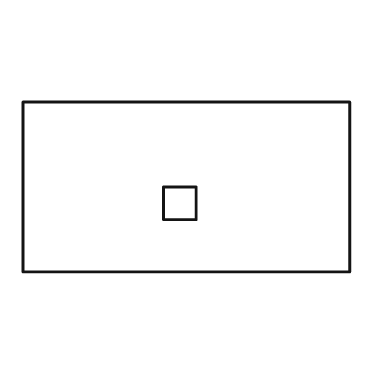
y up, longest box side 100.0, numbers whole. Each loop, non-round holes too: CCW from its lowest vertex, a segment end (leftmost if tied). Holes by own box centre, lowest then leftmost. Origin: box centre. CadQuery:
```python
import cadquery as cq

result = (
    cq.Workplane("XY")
    .moveTo(-50.0, -26.0)
    .lineTo(50.0, -26.0)
    .lineTo(50.0, 26.0)
    .lineTo(-50.0, 26.0)
    .close()
    .moveTo(-7.0, -10.0)
    .lineTo(3.0, -10.0)
    .lineTo(3.0, 0.0)
    .lineTo(-7.0, 0.0)
    .close()
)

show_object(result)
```